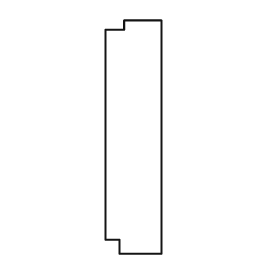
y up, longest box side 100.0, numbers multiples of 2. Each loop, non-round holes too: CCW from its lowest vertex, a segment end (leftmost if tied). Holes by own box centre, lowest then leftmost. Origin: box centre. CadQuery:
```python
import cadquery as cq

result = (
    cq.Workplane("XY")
    .moveTo(-6.0, -50.0)
    .lineTo(12.0, -50.0)
    .lineTo(12.0, 50.0)
    .lineTo(-4.0, 50.0)
    .lineTo(-4.0, 46.0)
    .lineTo(-12.0, 46.0)
    .lineTo(-12.0, -44.0)
    .lineTo(-6.0, -44.0)
    .close()
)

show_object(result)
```